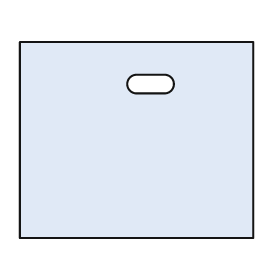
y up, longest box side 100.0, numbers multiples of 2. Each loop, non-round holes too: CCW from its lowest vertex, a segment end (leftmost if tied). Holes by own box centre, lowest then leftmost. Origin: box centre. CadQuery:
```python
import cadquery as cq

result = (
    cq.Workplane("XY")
    .moveTo(-50.0, -42.0)
    .lineTo(50.0, -42.0)
    .lineTo(50.0, 42.0)
    .lineTo(-50.0, 42.0)
    .close()
    .moveTo(0.0, 20.0)
    .lineTo(12.0, 20.0)
    .threePointArc((16.0, 24.0), (12.0, 28.0))
    .lineTo(0.0, 28.0)
    .threePointArc((-4.0, 24.0), (0.0, 20.0))
    .close()
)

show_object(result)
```